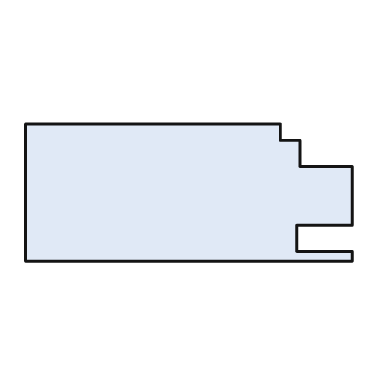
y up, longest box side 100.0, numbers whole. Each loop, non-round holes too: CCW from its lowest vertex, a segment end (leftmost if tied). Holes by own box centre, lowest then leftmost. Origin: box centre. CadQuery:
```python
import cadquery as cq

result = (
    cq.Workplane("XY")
    .moveTo(-50.0, -21.0)
    .lineTo(50.0, -21.0)
    .lineTo(50.0, -18.0)
    .lineTo(33.0, -18.0)
    .lineTo(33.0, -10.0)
    .lineTo(50.0, -10.0)
    .lineTo(50.0, 8.0)
    .lineTo(34.0, 8.0)
    .lineTo(34.0, 16.0)
    .lineTo(28.0, 16.0)
    .lineTo(28.0, 21.0)
    .lineTo(-50.0, 21.0)
    .close()
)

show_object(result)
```